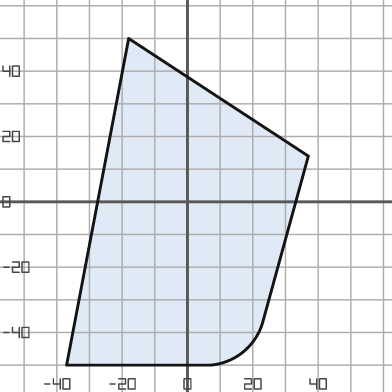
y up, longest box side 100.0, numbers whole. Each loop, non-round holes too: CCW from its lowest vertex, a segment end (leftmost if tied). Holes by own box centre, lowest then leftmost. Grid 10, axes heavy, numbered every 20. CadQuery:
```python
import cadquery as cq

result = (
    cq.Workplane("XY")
    .moveTo(-37.0, -50.0)
    .lineTo(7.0, -50.0)
    .threePointArc((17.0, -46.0), (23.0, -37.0))
    .lineTo(37.0, 14.0)
    .lineTo(-18.0, 50.0)
    .close()
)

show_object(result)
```